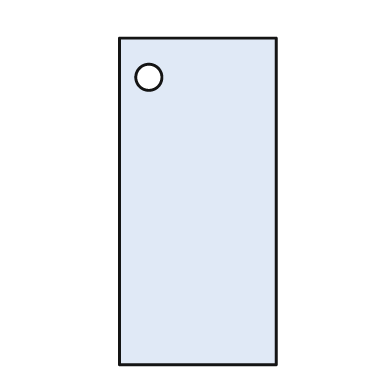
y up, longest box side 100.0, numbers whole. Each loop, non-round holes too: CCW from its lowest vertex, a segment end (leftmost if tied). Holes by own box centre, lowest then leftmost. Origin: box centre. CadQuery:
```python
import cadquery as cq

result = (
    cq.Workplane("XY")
    .moveTo(-24.0, -50.0)
    .lineTo(24.0, -50.0)
    .lineTo(24.0, 50.0)
    .lineTo(-24.0, 50.0)
    .close()
    .moveTo(-15.0, 38.0)
    .circle(4.0)
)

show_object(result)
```